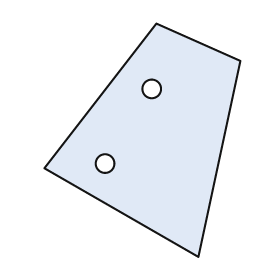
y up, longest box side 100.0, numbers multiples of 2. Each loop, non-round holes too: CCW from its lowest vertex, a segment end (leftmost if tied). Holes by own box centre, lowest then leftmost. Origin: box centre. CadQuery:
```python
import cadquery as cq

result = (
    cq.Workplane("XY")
    .moveTo(24.0, -50.0)
    .lineTo(42.0, 34.0)
    .lineTo(6.0, 50.0)
    .lineTo(-42.0, -12.0)
    .close()
    .moveTo(-16.0, -10.0)
    .circle(4.0)
    .moveTo(4.0, 22.0)
    .circle(4.0)
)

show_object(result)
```